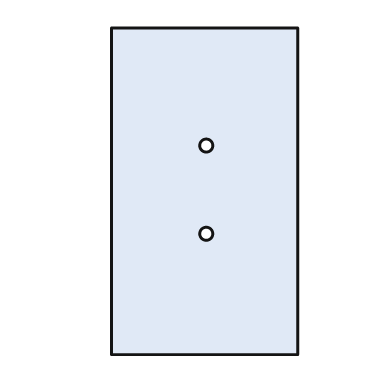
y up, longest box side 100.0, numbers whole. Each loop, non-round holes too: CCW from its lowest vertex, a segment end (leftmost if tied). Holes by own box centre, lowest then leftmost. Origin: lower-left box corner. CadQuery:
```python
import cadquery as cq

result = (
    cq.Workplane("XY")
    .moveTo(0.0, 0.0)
    .lineTo(57.0, 0.0)
    .lineTo(57.0, 100.0)
    .lineTo(0.0, 100.0)
    .close()
    .moveTo(29.0, 37.0)
    .circle(2.0)
    .moveTo(29.0, 64.0)
    .circle(2.0)
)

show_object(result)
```